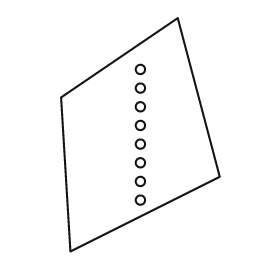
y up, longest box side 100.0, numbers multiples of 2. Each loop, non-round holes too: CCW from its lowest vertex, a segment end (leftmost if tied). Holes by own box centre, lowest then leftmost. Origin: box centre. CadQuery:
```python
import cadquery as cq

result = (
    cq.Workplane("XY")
    .moveTo(-30.0, -50.0)
    .lineTo(34.0, -18.0)
    .lineTo(16.0, 50.0)
    .lineTo(-34.0, 16.0)
    .close()
    .moveTo(0.0, -28.0)
    .circle(2.0)
    .moveTo(0.0, -20.0)
    .circle(2.0)
    .moveTo(0.0, -12.0)
    .circle(2.0)
    .moveTo(0.0, -4.0)
    .circle(2.0)
    .moveTo(0.0, 4.0)
    .circle(2.0)
    .moveTo(0.0, 12.0)
    .circle(2.0)
    .moveTo(0.0, 20.0)
    .circle(2.0)
    .moveTo(0.0, 28.0)
    .circle(2.0)
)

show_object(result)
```